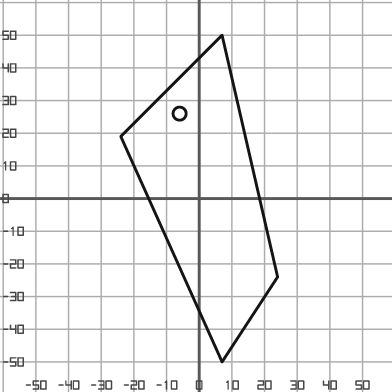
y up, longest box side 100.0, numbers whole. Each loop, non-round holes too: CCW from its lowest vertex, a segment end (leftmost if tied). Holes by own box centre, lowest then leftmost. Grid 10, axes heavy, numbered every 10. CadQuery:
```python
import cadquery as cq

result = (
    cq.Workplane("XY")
    .moveTo(7.0, -50.0)
    .lineTo(24.0, -24.0)
    .lineTo(7.0, 50.0)
    .lineTo(-24.0, 19.0)
    .close()
    .moveTo(-6.0, 26.0)
    .circle(2.0)
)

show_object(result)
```